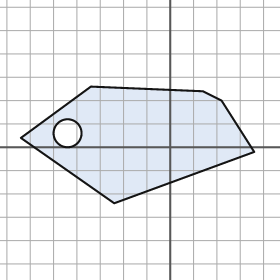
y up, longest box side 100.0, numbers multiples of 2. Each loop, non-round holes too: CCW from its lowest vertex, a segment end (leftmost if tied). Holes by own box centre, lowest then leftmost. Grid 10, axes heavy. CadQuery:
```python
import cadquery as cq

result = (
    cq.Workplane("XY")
    .moveTo(-24.0, -24.0)
    .lineTo(36.0, -2.0)
    .lineTo(22.0, 20.0)
    .lineTo(14.0, 24.0)
    .lineTo(-34.0, 26.0)
    .lineTo(-64.0, 4.0)
    .close()
    .moveTo(-44.0, 6.0)
    .circle(6.0)
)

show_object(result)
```